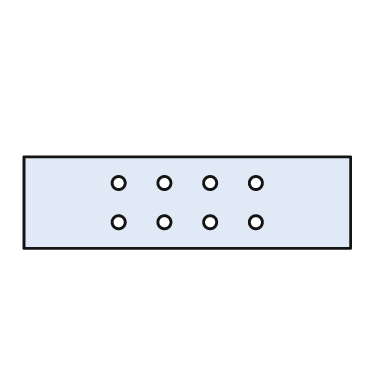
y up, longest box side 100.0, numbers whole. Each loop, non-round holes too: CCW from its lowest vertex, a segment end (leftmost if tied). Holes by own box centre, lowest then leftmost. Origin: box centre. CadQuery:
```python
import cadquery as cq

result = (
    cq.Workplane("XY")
    .moveTo(-50.0, -14.0)
    .lineTo(50.0, -14.0)
    .lineTo(50.0, 14.0)
    .lineTo(-50.0, 14.0)
    .close()
    .moveTo(-21.0, -6.0)
    .circle(2.0)
    .moveTo(-7.0, -6.0)
    .circle(2.0)
    .moveTo(7.0, -6.0)
    .circle(2.0)
    .moveTo(21.0, -6.0)
    .circle(2.0)
    .moveTo(-21.0, 6.0)
    .circle(2.0)
    .moveTo(-7.0, 6.0)
    .circle(2.0)
    .moveTo(7.0, 6.0)
    .circle(2.0)
    .moveTo(21.0, 6.0)
    .circle(2.0)
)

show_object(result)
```